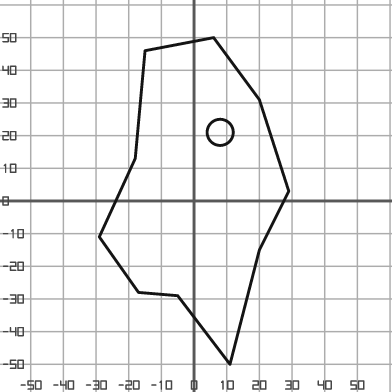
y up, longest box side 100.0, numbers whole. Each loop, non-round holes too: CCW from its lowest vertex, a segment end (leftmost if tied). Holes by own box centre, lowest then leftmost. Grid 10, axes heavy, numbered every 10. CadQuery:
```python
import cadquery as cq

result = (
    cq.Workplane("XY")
    .moveTo(11.0, -50.0)
    .lineTo(20.0, -15.0)
    .lineTo(29.0, 3.0)
    .lineTo(20.0, 31.0)
    .lineTo(6.0, 50.0)
    .lineTo(-15.0, 46.0)
    .lineTo(-18.0, 13.0)
    .lineTo(-29.0, -11.0)
    .lineTo(-17.0, -28.0)
    .lineTo(-5.0, -29.0)
    .close()
    .moveTo(8.0, 21.0)
    .circle(4.0)
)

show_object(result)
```